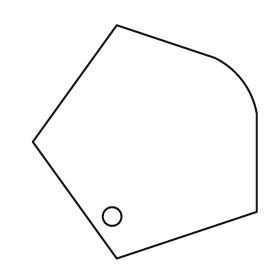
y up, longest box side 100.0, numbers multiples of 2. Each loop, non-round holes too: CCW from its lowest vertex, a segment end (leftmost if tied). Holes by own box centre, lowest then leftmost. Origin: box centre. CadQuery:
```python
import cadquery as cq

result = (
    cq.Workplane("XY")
    .moveTo(-12.0, -50.0)
    .lineTo(48.0, -30.0)
    .lineTo(48.0, 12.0)
    .threePointArc((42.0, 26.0), (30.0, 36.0))
    .lineTo(-12.0, 50.0)
    .lineTo(-48.0, 0.0)
    .close()
    .moveTo(-14.0, -32.0)
    .circle(4.0)
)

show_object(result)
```